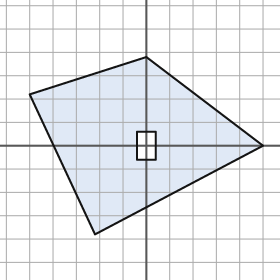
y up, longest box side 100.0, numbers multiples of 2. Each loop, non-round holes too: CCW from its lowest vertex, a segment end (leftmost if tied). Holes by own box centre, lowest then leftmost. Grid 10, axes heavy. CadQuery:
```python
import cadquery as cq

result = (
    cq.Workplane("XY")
    .moveTo(-22.0, -38.0)
    .lineTo(50.0, 0.0)
    .lineTo(0.0, 38.0)
    .lineTo(-50.0, 22.0)
    .close()
    .moveTo(-4.0, -6.0)
    .lineTo(4.0, -6.0)
    .lineTo(4.0, 6.0)
    .lineTo(-4.0, 6.0)
    .close()
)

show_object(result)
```